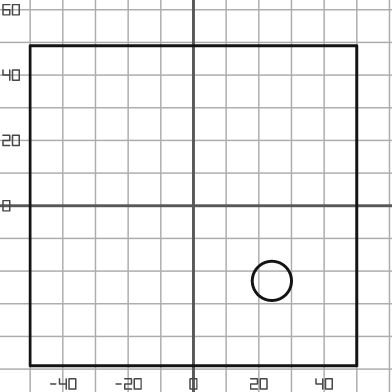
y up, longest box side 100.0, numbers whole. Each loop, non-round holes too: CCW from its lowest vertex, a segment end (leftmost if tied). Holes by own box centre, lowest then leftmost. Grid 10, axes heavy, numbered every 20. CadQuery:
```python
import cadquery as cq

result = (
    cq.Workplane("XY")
    .moveTo(-50.0, -49.0)
    .lineTo(50.0, -49.0)
    .lineTo(50.0, 49.0)
    .lineTo(-50.0, 49.0)
    .close()
    .moveTo(24.0, -23.0)
    .circle(6.0)
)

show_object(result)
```